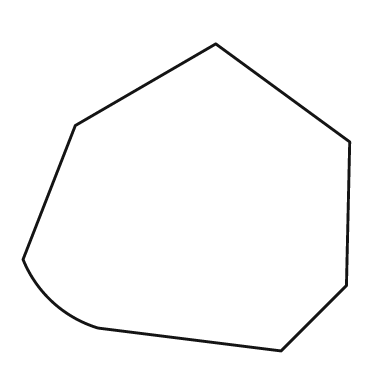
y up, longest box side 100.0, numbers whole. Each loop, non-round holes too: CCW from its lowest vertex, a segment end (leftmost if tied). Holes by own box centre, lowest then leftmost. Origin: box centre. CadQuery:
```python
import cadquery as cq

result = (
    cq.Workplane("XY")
    .moveTo(29.0, -47.0)
    .lineTo(49.0, -27.0)
    .lineTo(50.0, 17.0)
    .lineTo(9.0, 47.0)
    .lineTo(-34.0, 22.0)
    .lineTo(-50.0, -19.0)
    .threePointArc((-41.0, -32.0), (-27.0, -40.0))
    .close()
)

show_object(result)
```